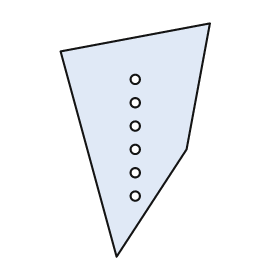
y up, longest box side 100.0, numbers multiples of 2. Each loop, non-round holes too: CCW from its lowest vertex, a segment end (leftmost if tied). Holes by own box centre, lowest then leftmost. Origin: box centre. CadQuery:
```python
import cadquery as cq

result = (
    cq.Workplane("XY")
    .moveTo(-8.0, -50.0)
    .lineTo(22.0, -4.0)
    .lineTo(32.0, 50.0)
    .lineTo(-32.0, 38.0)
    .close()
    .moveTo(0.0, -24.0)
    .circle(2.0)
    .moveTo(0.0, -14.0)
    .circle(2.0)
    .moveTo(0.0, -4.0)
    .circle(2.0)
    .moveTo(0.0, 6.0)
    .circle(2.0)
    .moveTo(0.0, 16.0)
    .circle(2.0)
    .moveTo(0.0, 26.0)
    .circle(2.0)
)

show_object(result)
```